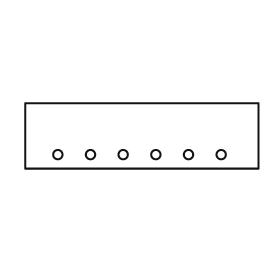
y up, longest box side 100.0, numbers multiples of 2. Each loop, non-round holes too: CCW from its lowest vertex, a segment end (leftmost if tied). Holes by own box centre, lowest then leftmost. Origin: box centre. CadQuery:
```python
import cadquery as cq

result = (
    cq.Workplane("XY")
    .moveTo(-50.0, -14.0)
    .lineTo(50.0, -14.0)
    .lineTo(50.0, 14.0)
    .lineTo(-50.0, 14.0)
    .close()
    .moveTo(-36.0, -8.0)
    .circle(2.0)
    .moveTo(-22.0, -8.0)
    .circle(2.0)
    .moveTo(-8.0, -8.0)
    .circle(2.0)
    .moveTo(6.0, -8.0)
    .circle(2.0)
    .moveTo(20.0, -8.0)
    .circle(2.0)
    .moveTo(34.0, -8.0)
    .circle(2.0)
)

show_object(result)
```